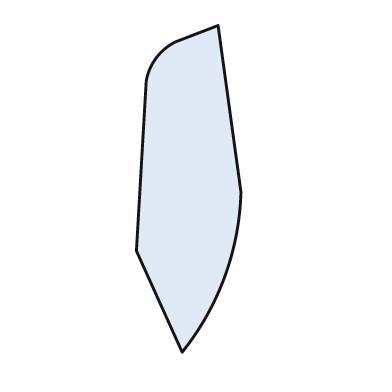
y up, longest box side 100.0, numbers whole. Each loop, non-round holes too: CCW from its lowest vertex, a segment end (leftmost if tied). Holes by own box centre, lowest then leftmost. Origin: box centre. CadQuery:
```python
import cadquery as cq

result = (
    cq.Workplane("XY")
    .moveTo(-2.0, -50.0)
    .threePointArc((11.0, -27.0), (16.0, -1.0))
    .lineTo(9.0, 50.0)
    .lineTo(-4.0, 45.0)
    .threePointArc((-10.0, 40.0), (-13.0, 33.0))
    .lineTo(-16.0, -19.0)
    .close()
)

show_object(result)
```